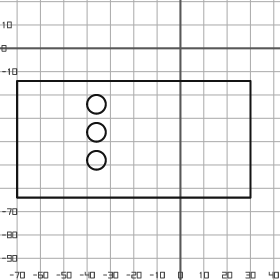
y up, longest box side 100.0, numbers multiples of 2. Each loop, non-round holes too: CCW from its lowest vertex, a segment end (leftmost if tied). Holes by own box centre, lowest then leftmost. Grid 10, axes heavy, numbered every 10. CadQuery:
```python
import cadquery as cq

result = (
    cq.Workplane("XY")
    .moveTo(-70.0, -64.0)
    .lineTo(30.0, -64.0)
    .lineTo(30.0, -14.0)
    .lineTo(-70.0, -14.0)
    .close()
    .moveTo(-36.0, -48.0)
    .circle(4.0)
    .moveTo(-36.0, -36.0)
    .circle(4.0)
    .moveTo(-36.0, -24.0)
    .circle(4.0)
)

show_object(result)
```